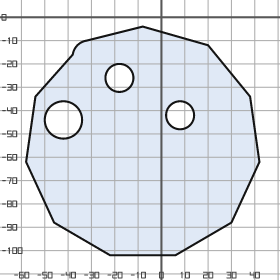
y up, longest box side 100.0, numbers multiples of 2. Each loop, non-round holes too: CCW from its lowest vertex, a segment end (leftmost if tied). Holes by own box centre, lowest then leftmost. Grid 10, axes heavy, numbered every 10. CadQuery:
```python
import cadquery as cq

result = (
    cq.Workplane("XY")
    .moveTo(-22.0, -102.0)
    .lineTo(6.0, -102.0)
    .lineTo(30.0, -88.0)
    .lineTo(42.0, -62.0)
    .lineTo(38.0, -34.0)
    .lineTo(20.0, -12.0)
    .lineTo(-8.0, -4.0)
    .lineTo(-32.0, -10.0)
    .threePointArc((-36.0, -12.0), (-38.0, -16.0))
    .lineTo(-54.0, -34.0)
    .lineTo(-58.0, -62.0)
    .lineTo(-46.0, -88.0)
    .close()
    .moveTo(-42.0, -44.0)
    .circle(8.0)
    .moveTo(8.0, -42.0)
    .circle(6.0)
    .moveTo(-18.0, -26.0)
    .circle(6.0)
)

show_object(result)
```